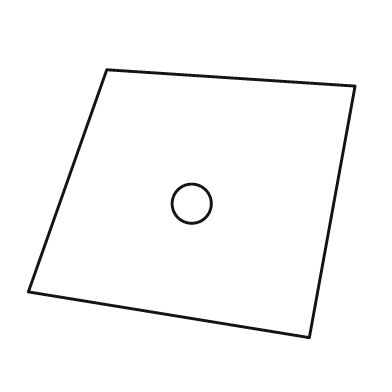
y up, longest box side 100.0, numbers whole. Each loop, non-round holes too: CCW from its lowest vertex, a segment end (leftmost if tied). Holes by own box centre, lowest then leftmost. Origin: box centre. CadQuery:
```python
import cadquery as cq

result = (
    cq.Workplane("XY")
    .moveTo(36.0, -41.0)
    .lineTo(50.0, 36.0)
    .lineTo(-26.0, 41.0)
    .lineTo(-50.0, -27.0)
    .close()
    .moveTo(0.0, 0.0)
    .circle(6.0)
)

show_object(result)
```